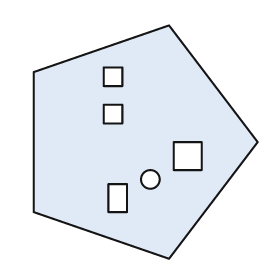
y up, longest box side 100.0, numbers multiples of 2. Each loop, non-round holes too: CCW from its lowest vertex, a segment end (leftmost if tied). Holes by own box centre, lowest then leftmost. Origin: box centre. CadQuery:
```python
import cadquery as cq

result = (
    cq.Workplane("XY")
    .moveTo(10.0, -50.0)
    .lineTo(48.0, 0.0)
    .lineTo(10.0, 50.0)
    .lineTo(-48.0, 30.0)
    .lineTo(-48.0, -30.0)
    .close()
    .moveTo(-16.0, -30.0)
    .lineTo(-8.0, -30.0)
    .lineTo(-8.0, -18.0)
    .lineTo(-16.0, -18.0)
    .close()
    .moveTo(2.0, -16.0)
    .circle(4.0)
    .moveTo(12.0, -12.0)
    .lineTo(24.0, -12.0)
    .lineTo(24.0, 0.0)
    .lineTo(12.0, 0.0)
    .close()
    .moveTo(-18.0, 8.0)
    .lineTo(-10.0, 8.0)
    .lineTo(-10.0, 16.0)
    .lineTo(-18.0, 16.0)
    .close()
    .moveTo(-18.0, 24.0)
    .lineTo(-10.0, 24.0)
    .lineTo(-10.0, 32.0)
    .lineTo(-18.0, 32.0)
    .close()
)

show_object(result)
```